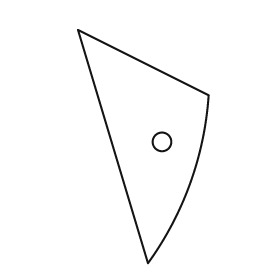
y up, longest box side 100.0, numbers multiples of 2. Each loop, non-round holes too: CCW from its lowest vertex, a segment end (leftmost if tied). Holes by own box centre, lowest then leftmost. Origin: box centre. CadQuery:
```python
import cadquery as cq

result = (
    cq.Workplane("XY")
    .moveTo(2.0, -50.0)
    .threePointArc((20.0, -16.0), (28.0, 22.0))
    .lineTo(-28.0, 50.0)
    .close()
    .moveTo(8.0, 2.0)
    .circle(4.0)
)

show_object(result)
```